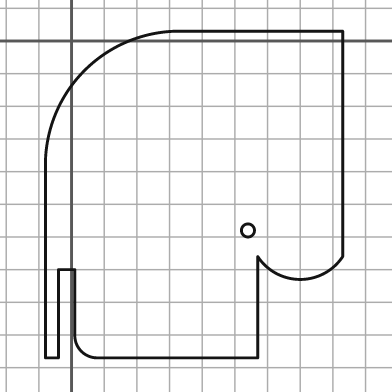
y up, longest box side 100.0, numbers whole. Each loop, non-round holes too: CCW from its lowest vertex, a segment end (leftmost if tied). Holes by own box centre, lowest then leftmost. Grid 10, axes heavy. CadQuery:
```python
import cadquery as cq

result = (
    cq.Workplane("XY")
    .moveTo(-8.0, -97.0)
    .lineTo(-4.0, -97.0)
    .lineTo(-4.0, -70.0)
    .lineTo(1.0, -70.0)
    .lineTo(1.0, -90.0)
    .threePointArc((3.0, -95.0), (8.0, -97.0))
    .lineTo(57.0, -97.0)
    .lineTo(57.0, -66.0)
    .threePointArc((70.0, -73.0), (83.0, -66.0))
    .lineTo(83.0, 3.0)
    .lineTo(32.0, 3.0)
    .threePointArc((4.0, -9.0), (-8.0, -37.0))
    .close()
    .moveTo(54.0, -58.0)
    .circle(2.0)
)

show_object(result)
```